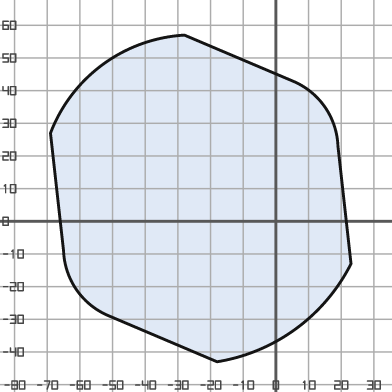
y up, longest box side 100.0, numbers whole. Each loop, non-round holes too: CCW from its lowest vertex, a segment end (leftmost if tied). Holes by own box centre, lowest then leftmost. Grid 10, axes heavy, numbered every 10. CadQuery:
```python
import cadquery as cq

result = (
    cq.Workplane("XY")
    .moveTo(-18.0, -43.0)
    .threePointArc((6.0, -33.0), (23.0, -13.0))
    .lineTo(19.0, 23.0)
    .threePointArc((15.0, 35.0), (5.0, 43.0))
    .lineTo(-28.0, 57.0)
    .threePointArc((-53.0, 48.0), (-69.0, 27.0))
    .lineTo(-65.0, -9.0)
    .threePointArc((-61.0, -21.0), (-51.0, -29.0))
    .close()
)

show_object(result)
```